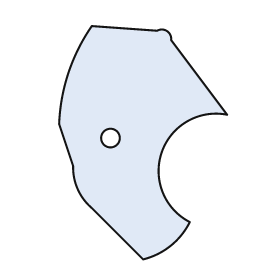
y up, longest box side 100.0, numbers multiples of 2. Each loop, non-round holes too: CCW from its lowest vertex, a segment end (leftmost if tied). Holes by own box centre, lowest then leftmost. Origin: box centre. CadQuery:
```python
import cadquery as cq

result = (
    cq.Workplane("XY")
    .moveTo(0.0, -50.0)
    .threePointArc((12.0, -44.0), (20.0, -34.0))
    .threePointArc((8.0, -4.0), (36.0, 12.0))
    .lineTo(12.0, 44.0)
    .threePointArc((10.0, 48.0), (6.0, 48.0))
    .lineTo(-22.0, 50.0)
    .threePointArc((-32.0, 30.0), (-36.0, 8.0))
    .lineTo(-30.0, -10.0)
    .threePointArc((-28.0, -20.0), (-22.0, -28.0))
    .close()
    .moveTo(-14.0, 2.0)
    .circle(4.0)
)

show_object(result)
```